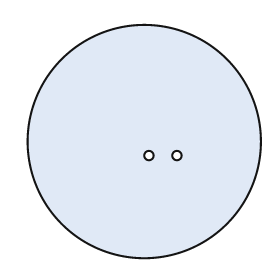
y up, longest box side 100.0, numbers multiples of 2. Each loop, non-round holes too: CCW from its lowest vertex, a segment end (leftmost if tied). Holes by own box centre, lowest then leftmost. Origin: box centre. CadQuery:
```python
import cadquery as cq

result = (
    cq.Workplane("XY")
    .moveTo(0.0, 0.0)
    .circle(50.0)
    .moveTo(2.0, -6.0)
    .circle(2.0)
    .moveTo(14.0, -6.0)
    .circle(2.0)
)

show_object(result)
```